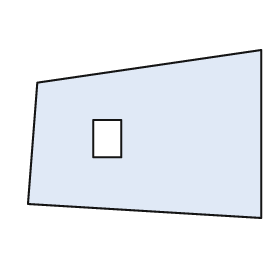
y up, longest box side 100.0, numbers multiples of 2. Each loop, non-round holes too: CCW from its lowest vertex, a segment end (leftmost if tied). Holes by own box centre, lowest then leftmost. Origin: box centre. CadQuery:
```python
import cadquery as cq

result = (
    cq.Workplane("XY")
    .moveTo(50.0, -36.0)
    .lineTo(50.0, 36.0)
    .lineTo(-46.0, 22.0)
    .lineTo(-50.0, -30.0)
    .close()
    .moveTo(-22.0, -10.0)
    .lineTo(-10.0, -10.0)
    .lineTo(-10.0, 6.0)
    .lineTo(-22.0, 6.0)
    .close()
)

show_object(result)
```